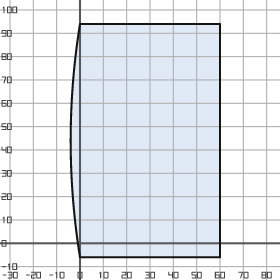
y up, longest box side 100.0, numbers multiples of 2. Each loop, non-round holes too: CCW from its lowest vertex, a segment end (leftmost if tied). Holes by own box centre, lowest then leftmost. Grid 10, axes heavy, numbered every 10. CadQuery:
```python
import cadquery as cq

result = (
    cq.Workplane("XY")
    .moveTo(0.0, -6.0)
    .lineTo(60.0, -6.0)
    .lineTo(60.0, 94.0)
    .lineTo(0.0, 94.0)
    .threePointArc((-4.0, 44.0), (0.0, -6.0))
    .close()
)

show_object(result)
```